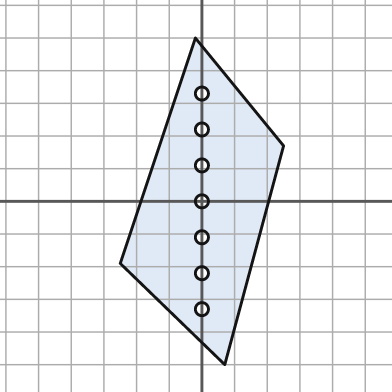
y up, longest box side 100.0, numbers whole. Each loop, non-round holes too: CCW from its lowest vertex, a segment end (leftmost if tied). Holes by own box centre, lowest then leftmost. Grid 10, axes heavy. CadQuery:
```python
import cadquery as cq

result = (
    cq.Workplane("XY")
    .moveTo(7.0, -50.0)
    .lineTo(25.0, 17.0)
    .lineTo(-2.0, 50.0)
    .lineTo(-25.0, -19.0)
    .close()
    .moveTo(0.0, -33.0)
    .circle(2.0)
    .moveTo(0.0, -22.0)
    .circle(2.0)
    .moveTo(0.0, -11.0)
    .circle(2.0)
    .moveTo(0.0, 0.0)
    .circle(2.0)
    .moveTo(0.0, 11.0)
    .circle(2.0)
    .moveTo(0.0, 22.0)
    .circle(2.0)
    .moveTo(0.0, 33.0)
    .circle(2.0)
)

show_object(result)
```